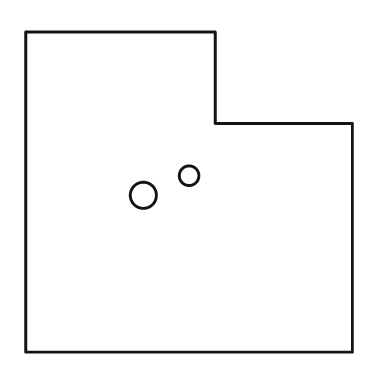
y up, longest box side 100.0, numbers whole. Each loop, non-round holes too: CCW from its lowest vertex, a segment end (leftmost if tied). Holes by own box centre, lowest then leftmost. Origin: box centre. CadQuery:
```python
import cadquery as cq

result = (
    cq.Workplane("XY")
    .moveTo(-50.0, -49.0)
    .lineTo(50.0, -49.0)
    .lineTo(50.0, 21.0)
    .lineTo(8.0, 21.0)
    .lineTo(8.0, 49.0)
    .lineTo(-50.0, 49.0)
    .close()
    .moveTo(-14.0, -1.0)
    .circle(4.0)
    .moveTo(0.0, 5.0)
    .circle(3.0)
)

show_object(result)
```